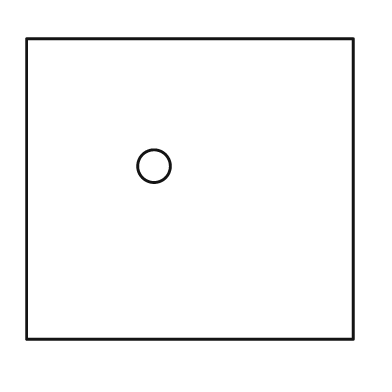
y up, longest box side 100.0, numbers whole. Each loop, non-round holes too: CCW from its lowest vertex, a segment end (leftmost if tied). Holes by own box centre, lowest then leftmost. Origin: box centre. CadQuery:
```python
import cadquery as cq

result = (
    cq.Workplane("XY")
    .moveTo(-50.0, -46.0)
    .lineTo(50.0, -46.0)
    .lineTo(50.0, 46.0)
    .lineTo(-50.0, 46.0)
    .close()
    .moveTo(-11.0, 7.0)
    .circle(5.0)
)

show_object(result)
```